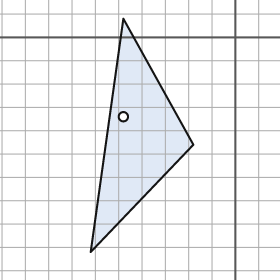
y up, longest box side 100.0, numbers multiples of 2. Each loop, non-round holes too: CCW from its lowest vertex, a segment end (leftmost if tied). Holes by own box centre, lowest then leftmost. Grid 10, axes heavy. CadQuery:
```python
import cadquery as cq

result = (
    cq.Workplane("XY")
    .moveTo(-62.0, -92.0)
    .lineTo(-18.0, -46.0)
    .lineTo(-48.0, 8.0)
    .close()
    .moveTo(-48.0, -34.0)
    .circle(2.0)
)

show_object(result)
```